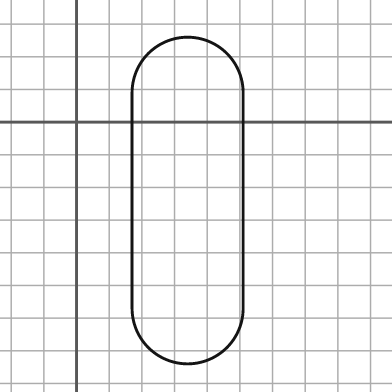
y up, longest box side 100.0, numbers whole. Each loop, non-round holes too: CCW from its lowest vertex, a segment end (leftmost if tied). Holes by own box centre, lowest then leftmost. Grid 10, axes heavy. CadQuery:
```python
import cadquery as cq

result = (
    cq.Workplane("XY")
    .moveTo(17.0, -57.0)
    .threePointArc((34.0, -74.0), (51.0, -57.0))
    .lineTo(51.0, 9.0)
    .threePointArc((34.0, 26.0), (17.0, 9.0))
    .close()
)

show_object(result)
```